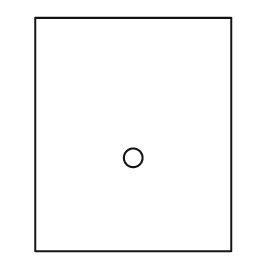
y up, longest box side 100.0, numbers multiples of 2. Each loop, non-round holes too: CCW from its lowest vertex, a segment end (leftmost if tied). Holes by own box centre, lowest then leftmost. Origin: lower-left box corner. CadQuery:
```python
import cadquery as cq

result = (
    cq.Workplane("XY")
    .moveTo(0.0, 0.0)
    .lineTo(84.0, 0.0)
    .lineTo(84.0, 100.0)
    .lineTo(0.0, 100.0)
    .close()
    .moveTo(42.0, 40.0)
    .circle(4.0)
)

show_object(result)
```